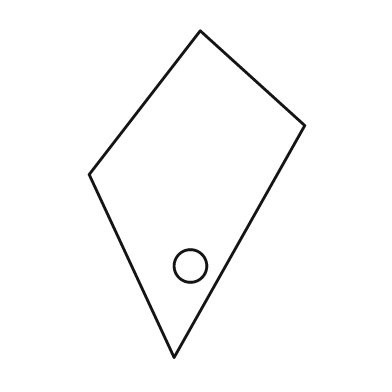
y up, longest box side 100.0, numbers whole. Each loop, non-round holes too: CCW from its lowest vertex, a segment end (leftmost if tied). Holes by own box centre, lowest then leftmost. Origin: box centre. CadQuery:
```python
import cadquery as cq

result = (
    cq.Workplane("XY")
    .moveTo(-7.0, -50.0)
    .lineTo(33.0, 21.0)
    .lineTo(1.0, 50.0)
    .lineTo(-33.0, 6.0)
    .close()
    .moveTo(-2.0, -22.0)
    .circle(5.0)
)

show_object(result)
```